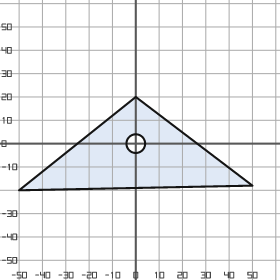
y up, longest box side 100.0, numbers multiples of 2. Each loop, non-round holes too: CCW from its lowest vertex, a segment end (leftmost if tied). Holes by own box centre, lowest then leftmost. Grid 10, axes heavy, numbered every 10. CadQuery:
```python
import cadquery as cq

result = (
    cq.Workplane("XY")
    .moveTo(-50.0, -20.0)
    .lineTo(50.0, -18.0)
    .lineTo(0.0, 20.0)
    .close()
    .moveTo(0.0, 0.0)
    .circle(4.0)
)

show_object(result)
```